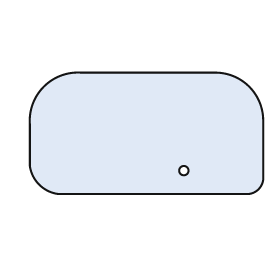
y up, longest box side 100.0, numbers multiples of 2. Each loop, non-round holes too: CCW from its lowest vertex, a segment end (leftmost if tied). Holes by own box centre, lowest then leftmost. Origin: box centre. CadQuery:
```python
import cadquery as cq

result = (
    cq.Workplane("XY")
    .moveTo(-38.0, -26.0)
    .lineTo(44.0, -26.0)
    .threePointArc((48.0, -24.0), (50.0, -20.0))
    .lineTo(50.0, 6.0)
    .threePointArc((44.0, 20.0), (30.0, 26.0))
    .lineTo(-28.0, 26.0)
    .threePointArc((-44.0, 20.0), (-50.0, 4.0))
    .lineTo(-50.0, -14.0)
    .threePointArc((-46.0, -22.0), (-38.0, -26.0))
    .close()
    .moveTo(16.0, -16.0)
    .circle(2.0)
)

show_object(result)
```